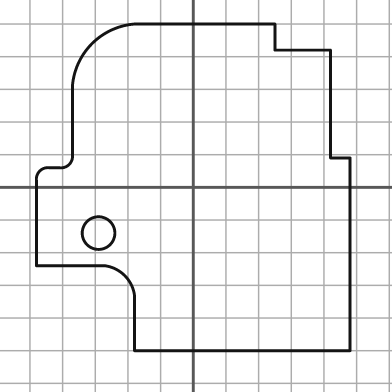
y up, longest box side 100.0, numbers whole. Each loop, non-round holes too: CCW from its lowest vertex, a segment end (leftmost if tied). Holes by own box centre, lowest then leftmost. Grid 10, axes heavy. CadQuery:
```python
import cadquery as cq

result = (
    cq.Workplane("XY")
    .moveTo(-18.0, -50.0)
    .lineTo(48.0, -50.0)
    .lineTo(48.0, 9.0)
    .lineTo(42.0, 9.0)
    .lineTo(42.0, 42.0)
    .lineTo(25.0, 42.0)
    .lineTo(25.0, 50.0)
    .lineTo(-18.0, 50.0)
    .threePointArc((-31.0, 44.0), (-37.0, 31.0))
    .lineTo(-37.0, 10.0)
    .threePointArc((-38.0, 7.0), (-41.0, 6.0))
    .lineTo(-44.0, 6.0)
    .threePointArc((-47.0, 5.0), (-48.0, 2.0))
    .lineTo(-48.0, -24.0)
    .lineTo(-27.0, -24.0)
    .threePointArc((-21.0, -27.0), (-18.0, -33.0))
    .close()
    .moveTo(-29.0, -14.0)
    .circle(5.0)
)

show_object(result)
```